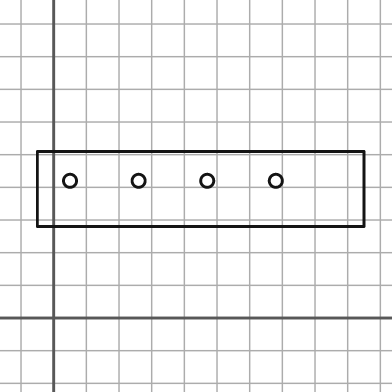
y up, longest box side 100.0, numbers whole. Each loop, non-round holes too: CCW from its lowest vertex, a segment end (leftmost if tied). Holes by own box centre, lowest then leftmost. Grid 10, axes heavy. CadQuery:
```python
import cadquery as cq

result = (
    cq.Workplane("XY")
    .moveTo(-5.0, 28.0)
    .lineTo(95.0, 28.0)
    .lineTo(95.0, 51.0)
    .lineTo(-5.0, 51.0)
    .close()
    .moveTo(5.0, 42.0)
    .circle(2.0)
    .moveTo(26.0, 42.0)
    .circle(2.0)
    .moveTo(47.0, 42.0)
    .circle(2.0)
    .moveTo(68.0, 42.0)
    .circle(2.0)
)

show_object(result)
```